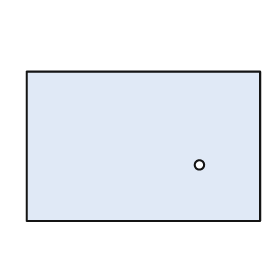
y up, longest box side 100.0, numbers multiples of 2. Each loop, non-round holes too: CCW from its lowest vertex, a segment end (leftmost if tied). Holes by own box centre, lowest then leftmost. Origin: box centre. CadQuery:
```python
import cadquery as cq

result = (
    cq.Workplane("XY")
    .moveTo(-50.0, -32.0)
    .lineTo(50.0, -32.0)
    .lineTo(50.0, 32.0)
    .lineTo(-50.0, 32.0)
    .close()
    .moveTo(24.0, -8.0)
    .circle(2.0)
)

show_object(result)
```